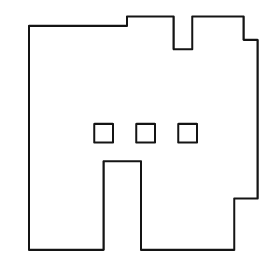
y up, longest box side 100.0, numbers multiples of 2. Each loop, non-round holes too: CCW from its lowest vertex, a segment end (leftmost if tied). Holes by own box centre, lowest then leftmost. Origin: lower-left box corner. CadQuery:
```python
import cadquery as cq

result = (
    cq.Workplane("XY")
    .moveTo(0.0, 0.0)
    .lineTo(32.0, 0.0)
    .lineTo(32.0, 38.0)
    .lineTo(48.0, 38.0)
    .lineTo(48.0, 0.0)
    .lineTo(88.0, 0.0)
    .lineTo(88.0, 22.0)
    .lineTo(98.0, 22.0)
    .lineTo(98.0, 90.0)
    .lineTo(92.0, 90.0)
    .lineTo(92.0, 100.0)
    .lineTo(70.0, 100.0)
    .lineTo(70.0, 86.0)
    .lineTo(62.0, 86.0)
    .lineTo(62.0, 100.0)
    .lineTo(42.0, 100.0)
    .lineTo(42.0, 96.0)
    .lineTo(0.0, 96.0)
    .close()
    .moveTo(28.0, 46.0)
    .lineTo(36.0, 46.0)
    .lineTo(36.0, 54.0)
    .lineTo(28.0, 54.0)
    .close()
    .moveTo(46.0, 46.0)
    .lineTo(54.0, 46.0)
    .lineTo(54.0, 54.0)
    .lineTo(46.0, 54.0)
    .close()
    .moveTo(64.0, 46.0)
    .lineTo(72.0, 46.0)
    .lineTo(72.0, 54.0)
    .lineTo(64.0, 54.0)
    .close()
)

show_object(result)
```